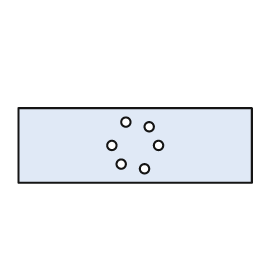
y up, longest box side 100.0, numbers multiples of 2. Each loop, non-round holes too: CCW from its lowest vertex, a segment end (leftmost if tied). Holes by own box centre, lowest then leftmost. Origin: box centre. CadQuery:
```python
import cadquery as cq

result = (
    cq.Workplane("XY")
    .moveTo(-50.0, -16.0)
    .lineTo(50.0, -16.0)
    .lineTo(50.0, 16.0)
    .lineTo(-50.0, 16.0)
    .close()
    .moveTo(4.0, -10.0)
    .circle(2.0)
    .moveTo(-6.0, -8.0)
    .circle(2.0)
    .moveTo(-10.0, 0.0)
    .circle(2.0)
    .moveTo(10.0, 0.0)
    .circle(2.0)
    .moveTo(6.0, 8.0)
    .circle(2.0)
    .moveTo(-4.0, 10.0)
    .circle(2.0)
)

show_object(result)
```